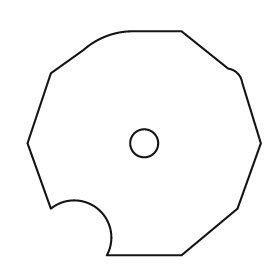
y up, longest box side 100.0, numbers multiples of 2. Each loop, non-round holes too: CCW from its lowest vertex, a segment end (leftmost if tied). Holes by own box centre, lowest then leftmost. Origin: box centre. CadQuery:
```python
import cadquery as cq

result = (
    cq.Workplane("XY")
    .moveTo(-16.0, -48.0)
    .lineTo(16.0, -48.0)
    .lineTo(40.0, -28.0)
    .lineTo(50.0, 0.0)
    .lineTo(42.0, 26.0)
    .threePointArc((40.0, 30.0), (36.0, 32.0))
    .lineTo(16.0, 48.0)
    .lineTo(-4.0, 48.0)
    .threePointArc((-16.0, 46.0), (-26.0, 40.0))
    .lineTo(-40.0, 30.0)
    .lineTo(-50.0, 0.0)
    .lineTo(-40.0, -28.0)
    .threePointArc((-20.0, -28.0), (-16.0, -48.0))
    .close()
    .moveTo(0.0, 0.0)
    .circle(6.0)
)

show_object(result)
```